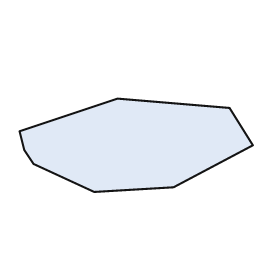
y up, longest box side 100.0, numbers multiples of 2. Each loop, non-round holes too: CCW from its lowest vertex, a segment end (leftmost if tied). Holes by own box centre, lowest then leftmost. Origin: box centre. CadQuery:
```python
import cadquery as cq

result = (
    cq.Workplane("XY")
    .moveTo(-18.0, -20.0)
    .lineTo(16.0, -18.0)
    .lineTo(50.0, 0.0)
    .lineTo(40.0, 16.0)
    .lineTo(-8.0, 20.0)
    .lineTo(-50.0, 6.0)
    .lineTo(-48.0, -2.0)
    .lineTo(-44.0, -8.0)
    .close()
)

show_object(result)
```